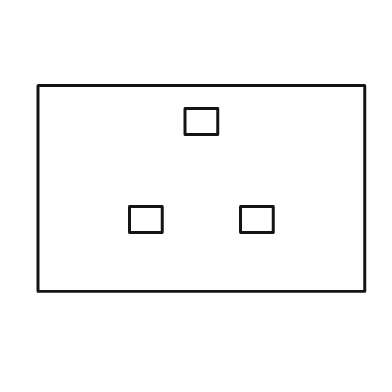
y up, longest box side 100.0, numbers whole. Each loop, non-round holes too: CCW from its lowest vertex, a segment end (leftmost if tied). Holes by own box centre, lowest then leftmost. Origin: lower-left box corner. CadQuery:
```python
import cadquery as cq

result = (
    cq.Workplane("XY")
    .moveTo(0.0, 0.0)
    .lineTo(100.0, 0.0)
    .lineTo(100.0, 63.0)
    .lineTo(0.0, 63.0)
    .close()
    .moveTo(28.0, 18.0)
    .lineTo(38.0, 18.0)
    .lineTo(38.0, 26.0)
    .lineTo(28.0, 26.0)
    .close()
    .moveTo(62.0, 18.0)
    .lineTo(72.0, 18.0)
    .lineTo(72.0, 26.0)
    .lineTo(62.0, 26.0)
    .close()
    .moveTo(45.0, 48.0)
    .lineTo(55.0, 48.0)
    .lineTo(55.0, 56.0)
    .lineTo(45.0, 56.0)
    .close()
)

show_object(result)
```